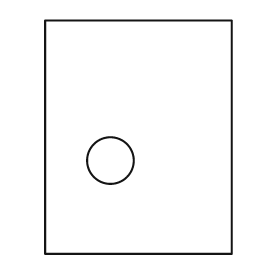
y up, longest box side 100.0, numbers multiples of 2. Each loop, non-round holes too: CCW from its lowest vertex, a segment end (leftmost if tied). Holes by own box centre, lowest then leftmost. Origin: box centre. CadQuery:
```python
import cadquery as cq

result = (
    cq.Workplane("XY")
    .moveTo(-40.0, -50.0)
    .lineTo(40.0, -50.0)
    .lineTo(40.0, 50.0)
    .lineTo(-40.0, 50.0)
    .close()
    .moveTo(-12.0, -10.0)
    .circle(10.0)
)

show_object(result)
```